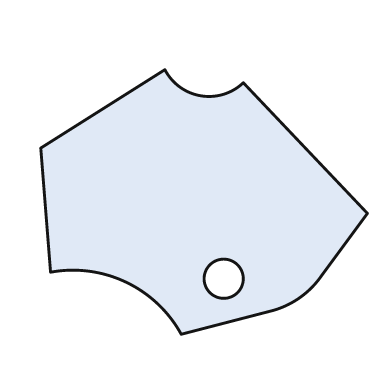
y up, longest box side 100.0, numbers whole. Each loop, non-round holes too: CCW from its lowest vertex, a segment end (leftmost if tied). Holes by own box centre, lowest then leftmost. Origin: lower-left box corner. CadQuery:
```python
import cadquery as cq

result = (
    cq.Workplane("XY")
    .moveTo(43.0, 0.0)
    .lineTo(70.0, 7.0)
    .threePointArc((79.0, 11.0), (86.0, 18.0))
    .lineTo(100.0, 37.0)
    .lineTo(62.0, 77.0)
    .threePointArc((49.0, 73.0), (38.0, 81.0))
    .lineTo(0.0, 57.0)
    .lineTo(3.0, 19.0)
    .threePointArc((26.0, 16.0), (43.0, 0.0))
    .close()
    .moveTo(56.0, 17.0)
    .circle(6.0)
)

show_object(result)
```